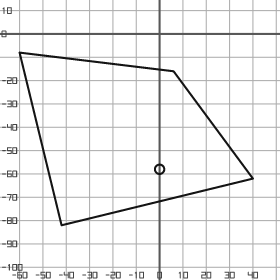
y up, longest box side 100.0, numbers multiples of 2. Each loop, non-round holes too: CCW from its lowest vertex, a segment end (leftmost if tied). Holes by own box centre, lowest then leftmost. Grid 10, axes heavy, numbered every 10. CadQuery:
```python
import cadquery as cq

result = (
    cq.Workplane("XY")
    .moveTo(-42.0, -82.0)
    .lineTo(40.0, -62.0)
    .lineTo(6.0, -16.0)
    .lineTo(-60.0, -8.0)
    .close()
    .moveTo(0.0, -58.0)
    .circle(2.0)
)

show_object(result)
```